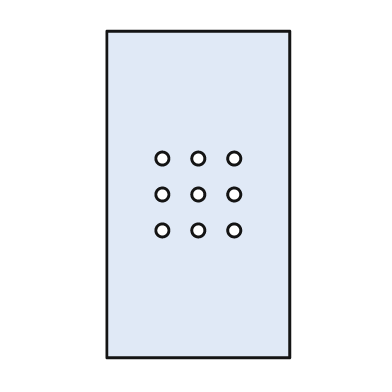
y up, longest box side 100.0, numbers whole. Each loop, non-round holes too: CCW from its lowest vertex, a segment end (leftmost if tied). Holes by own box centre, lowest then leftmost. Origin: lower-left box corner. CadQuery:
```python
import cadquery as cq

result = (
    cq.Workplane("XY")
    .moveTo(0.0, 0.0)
    .lineTo(56.0, 0.0)
    .lineTo(56.0, 100.0)
    .lineTo(0.0, 100.0)
    .close()
    .moveTo(17.0, 39.0)
    .circle(2.0)
    .moveTo(28.0, 39.0)
    .circle(2.0)
    .moveTo(39.0, 39.0)
    .circle(2.0)
    .moveTo(17.0, 50.0)
    .circle(2.0)
    .moveTo(28.0, 50.0)
    .circle(2.0)
    .moveTo(39.0, 50.0)
    .circle(2.0)
    .moveTo(17.0, 61.0)
    .circle(2.0)
    .moveTo(28.0, 61.0)
    .circle(2.0)
    .moveTo(39.0, 61.0)
    .circle(2.0)
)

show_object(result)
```